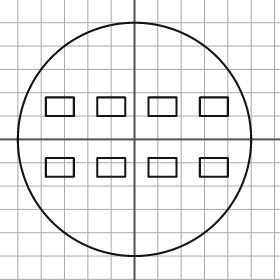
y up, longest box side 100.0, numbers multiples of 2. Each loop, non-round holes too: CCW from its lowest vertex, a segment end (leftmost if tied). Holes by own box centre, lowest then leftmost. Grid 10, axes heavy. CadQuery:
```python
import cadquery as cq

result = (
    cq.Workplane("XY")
    .moveTo(0.0, 0.0)
    .circle(50.0)
    .moveTo(-38.0, -16.0)
    .lineTo(-26.0, -16.0)
    .lineTo(-26.0, -8.0)
    .lineTo(-38.0, -8.0)
    .close()
    .moveTo(-16.0, -16.0)
    .lineTo(-4.0, -16.0)
    .lineTo(-4.0, -8.0)
    .lineTo(-16.0, -8.0)
    .close()
    .moveTo(6.0, -16.0)
    .lineTo(18.0, -16.0)
    .lineTo(18.0, -8.0)
    .lineTo(6.0, -8.0)
    .close()
    .moveTo(28.0, -16.0)
    .lineTo(40.0, -16.0)
    .lineTo(40.0, -8.0)
    .lineTo(28.0, -8.0)
    .close()
    .moveTo(-38.0, 10.0)
    .lineTo(-26.0, 10.0)
    .lineTo(-26.0, 18.0)
    .lineTo(-38.0, 18.0)
    .close()
    .moveTo(-16.0, 10.0)
    .lineTo(-4.0, 10.0)
    .lineTo(-4.0, 18.0)
    .lineTo(-16.0, 18.0)
    .close()
    .moveTo(6.0, 10.0)
    .lineTo(18.0, 10.0)
    .lineTo(18.0, 18.0)
    .lineTo(6.0, 18.0)
    .close()
    .moveTo(28.0, 10.0)
    .lineTo(40.0, 10.0)
    .lineTo(40.0, 18.0)
    .lineTo(28.0, 18.0)
    .close()
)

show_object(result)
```